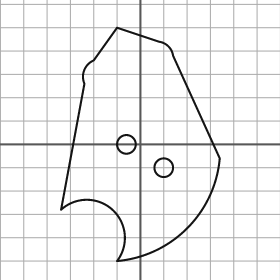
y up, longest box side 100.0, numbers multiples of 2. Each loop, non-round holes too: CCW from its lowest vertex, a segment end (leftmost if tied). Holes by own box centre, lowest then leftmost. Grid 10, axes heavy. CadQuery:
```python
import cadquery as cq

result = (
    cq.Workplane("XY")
    .moveTo(-10.0, -50.0)
    .threePointArc((20.0, -36.0), (34.0, -6.0))
    .lineTo(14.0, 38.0)
    .threePointArc((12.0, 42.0), (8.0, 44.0))
    .lineTo(-10.0, 50.0)
    .lineTo(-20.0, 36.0)
    .threePointArc((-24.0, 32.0), (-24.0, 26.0))
    .lineTo(-34.0, -28.0)
    .threePointArc((-12.0, -28.0), (-10.0, -50.0))
    .close()
    .moveTo(10.0, -10.0)
    .circle(4.0)
    .moveTo(-6.0, 0.0)
    .circle(4.0)
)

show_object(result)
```